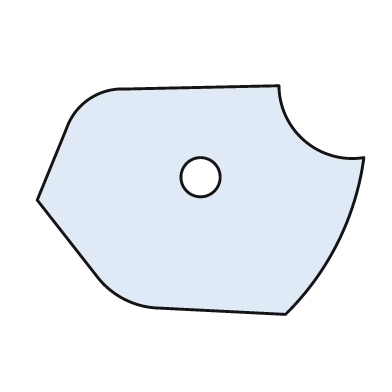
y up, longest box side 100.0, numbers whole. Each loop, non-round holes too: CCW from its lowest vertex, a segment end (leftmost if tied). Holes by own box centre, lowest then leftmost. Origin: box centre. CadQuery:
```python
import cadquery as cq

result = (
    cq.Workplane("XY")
    .moveTo(26.0, -35.0)
    .threePointArc((42.0, -13.0), (50.0, 13.0))
    .threePointArc((32.0, 18.0), (24.0, 35.0))
    .lineTo(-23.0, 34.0)
    .threePointArc((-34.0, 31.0), (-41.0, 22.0))
    .lineTo(-50.0, 0.0)
    .lineTo(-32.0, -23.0)
    .threePointArc((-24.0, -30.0), (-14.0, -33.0))
    .close()
    .moveTo(0.0, 7.0)
    .circle(6.0)
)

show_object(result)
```